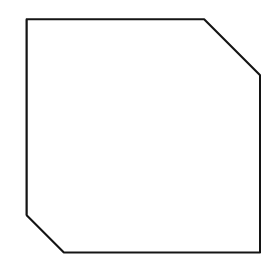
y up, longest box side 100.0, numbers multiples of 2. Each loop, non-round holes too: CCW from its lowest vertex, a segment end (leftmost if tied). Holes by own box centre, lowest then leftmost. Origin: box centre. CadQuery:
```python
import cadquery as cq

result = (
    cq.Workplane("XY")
    .moveTo(-34.0, -50.0)
    .lineTo(50.0, -50.0)
    .lineTo(50.0, 26.0)
    .lineTo(26.0, 50.0)
    .lineTo(-50.0, 50.0)
    .lineTo(-50.0, -34.0)
    .close()
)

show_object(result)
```